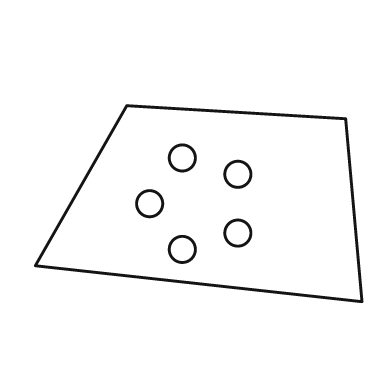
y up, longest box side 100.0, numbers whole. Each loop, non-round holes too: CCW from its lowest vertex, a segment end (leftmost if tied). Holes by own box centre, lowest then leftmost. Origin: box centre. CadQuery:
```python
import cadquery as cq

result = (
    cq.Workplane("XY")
    .moveTo(50.0, -30.0)
    .lineTo(45.0, 26.0)
    .lineTo(-22.0, 30.0)
    .lineTo(-50.0, -19.0)
    .close()
    .moveTo(-5.0, -14.0)
    .circle(4.0)
    .moveTo(12.0, -9.0)
    .circle(4.0)
    .moveTo(-15.0, 0.0)
    .circle(4.0)
    .moveTo(12.0, 9.0)
    .circle(4.0)
    .moveTo(-5.0, 14.0)
    .circle(4.0)
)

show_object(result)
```